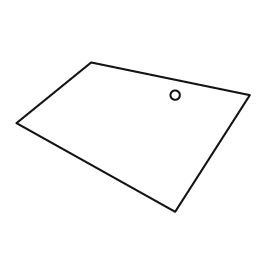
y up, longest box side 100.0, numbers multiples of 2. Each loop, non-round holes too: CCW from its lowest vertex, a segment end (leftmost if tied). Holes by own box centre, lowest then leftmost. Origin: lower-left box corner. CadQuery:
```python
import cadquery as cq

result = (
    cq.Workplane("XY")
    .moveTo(68.0, 0.0)
    .lineTo(100.0, 50.0)
    .lineTo(32.0, 64.0)
    .lineTo(0.0, 38.0)
    .close()
    .moveTo(68.0, 50.0)
    .circle(2.0)
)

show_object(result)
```